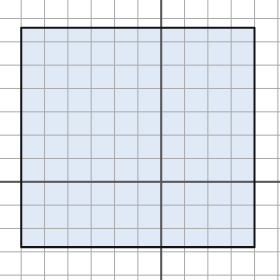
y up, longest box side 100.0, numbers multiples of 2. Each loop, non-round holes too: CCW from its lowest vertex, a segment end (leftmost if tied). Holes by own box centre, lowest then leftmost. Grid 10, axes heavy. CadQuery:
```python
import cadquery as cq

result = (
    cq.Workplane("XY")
    .moveTo(-60.0, -28.0)
    .lineTo(40.0, -28.0)
    .lineTo(40.0, 66.0)
    .lineTo(-60.0, 66.0)
    .close()
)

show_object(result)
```